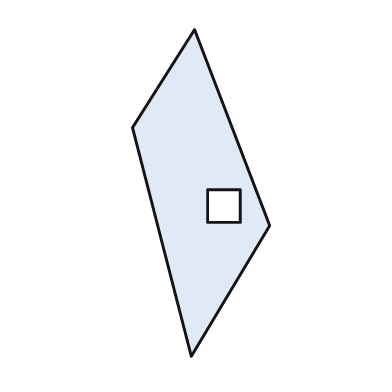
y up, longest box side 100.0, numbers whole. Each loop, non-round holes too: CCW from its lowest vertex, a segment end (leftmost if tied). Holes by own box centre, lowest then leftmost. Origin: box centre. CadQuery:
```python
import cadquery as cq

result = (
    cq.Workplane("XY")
    .moveTo(-3.0, -50.0)
    .lineTo(21.0, -10.0)
    .lineTo(-2.0, 50.0)
    .lineTo(-21.0, 20.0)
    .close()
    .moveTo(2.0, -9.0)
    .lineTo(12.0, -9.0)
    .lineTo(12.0, 1.0)
    .lineTo(2.0, 1.0)
    .close()
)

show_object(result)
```